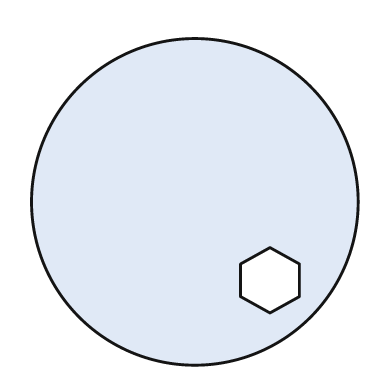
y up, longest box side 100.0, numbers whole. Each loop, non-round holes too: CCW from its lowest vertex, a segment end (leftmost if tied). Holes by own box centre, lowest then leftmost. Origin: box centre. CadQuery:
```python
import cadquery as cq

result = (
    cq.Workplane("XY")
    .moveTo(0.0, 0.0)
    .circle(50.0)
    .moveTo(23.0, -34.0)
    .lineTo(32.0, -29.0)
    .lineTo(32.0, -19.0)
    .lineTo(23.0, -14.0)
    .lineTo(14.0, -19.0)
    .lineTo(14.0, -29.0)
    .close()
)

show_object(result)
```